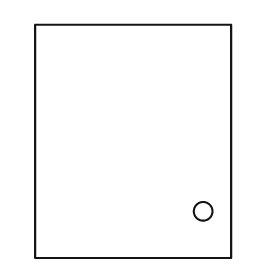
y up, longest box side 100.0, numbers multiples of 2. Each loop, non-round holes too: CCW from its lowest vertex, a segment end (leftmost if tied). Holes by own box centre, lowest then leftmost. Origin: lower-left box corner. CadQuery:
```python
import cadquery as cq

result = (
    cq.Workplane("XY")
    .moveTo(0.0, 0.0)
    .lineTo(84.0, 0.0)
    .lineTo(84.0, 100.0)
    .lineTo(0.0, 100.0)
    .close()
    .moveTo(72.0, 20.0)
    .circle(4.0)
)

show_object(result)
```